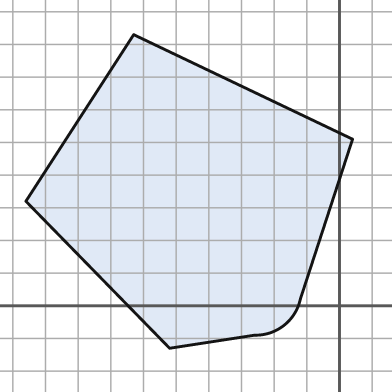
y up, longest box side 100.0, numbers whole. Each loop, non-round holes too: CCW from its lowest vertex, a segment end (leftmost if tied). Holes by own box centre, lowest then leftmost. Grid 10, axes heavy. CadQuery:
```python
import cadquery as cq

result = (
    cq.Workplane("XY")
    .moveTo(-52.0, -13.0)
    .lineTo(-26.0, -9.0)
    .threePointArc((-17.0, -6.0), (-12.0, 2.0))
    .lineTo(4.0, 51.0)
    .lineTo(-63.0, 83.0)
    .lineTo(-96.0, 32.0)
    .close()
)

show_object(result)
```